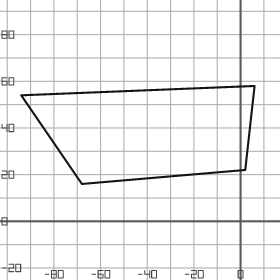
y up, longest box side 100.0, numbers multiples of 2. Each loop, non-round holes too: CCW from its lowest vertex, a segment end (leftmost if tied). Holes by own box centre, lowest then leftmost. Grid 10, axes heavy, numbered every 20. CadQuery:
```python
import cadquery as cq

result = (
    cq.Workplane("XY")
    .moveTo(-68.0, 16.0)
    .lineTo(2.0, 22.0)
    .lineTo(6.0, 58.0)
    .lineTo(-94.0, 54.0)
    .close()
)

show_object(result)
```